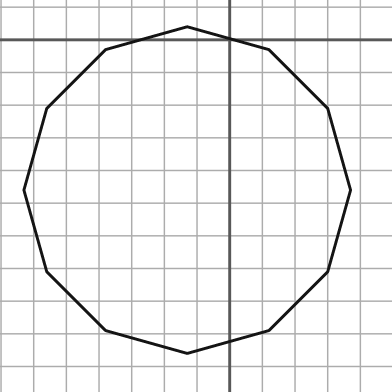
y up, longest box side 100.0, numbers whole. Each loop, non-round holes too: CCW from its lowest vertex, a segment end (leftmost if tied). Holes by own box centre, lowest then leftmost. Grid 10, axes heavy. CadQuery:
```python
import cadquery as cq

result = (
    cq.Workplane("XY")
    .moveTo(-13.0, -96.0)
    .lineTo(12.0, -89.0)
    .lineTo(30.0, -71.0)
    .lineTo(37.0, -46.0)
    .lineTo(30.0, -21.0)
    .lineTo(12.0, -3.0)
    .lineTo(-13.0, 4.0)
    .lineTo(-38.0, -3.0)
    .lineTo(-56.0, -21.0)
    .lineTo(-63.0, -46.0)
    .lineTo(-56.0, -71.0)
    .lineTo(-38.0, -89.0)
    .close()
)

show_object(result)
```